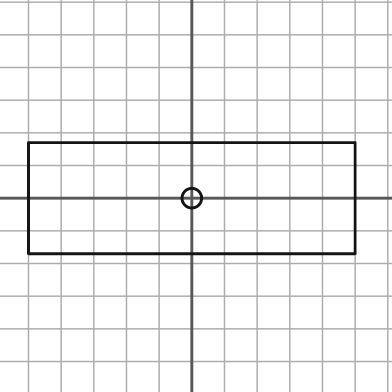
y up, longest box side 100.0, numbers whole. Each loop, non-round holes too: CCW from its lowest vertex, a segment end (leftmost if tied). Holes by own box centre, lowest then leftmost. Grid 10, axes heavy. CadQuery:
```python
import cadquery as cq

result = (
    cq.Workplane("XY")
    .moveTo(-50.0, -17.0)
    .lineTo(50.0, -17.0)
    .lineTo(50.0, 17.0)
    .lineTo(-50.0, 17.0)
    .close()
    .moveTo(0.0, 0.0)
    .circle(3.0)
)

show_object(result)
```